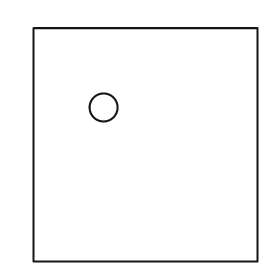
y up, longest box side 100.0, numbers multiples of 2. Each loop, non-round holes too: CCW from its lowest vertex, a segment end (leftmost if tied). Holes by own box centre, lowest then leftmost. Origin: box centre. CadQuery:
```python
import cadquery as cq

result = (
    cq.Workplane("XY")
    .moveTo(-48.0, -50.0)
    .lineTo(48.0, -50.0)
    .lineTo(48.0, 50.0)
    .lineTo(-48.0, 50.0)
    .close()
    .moveTo(-18.0, 16.0)
    .circle(6.0)
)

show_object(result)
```